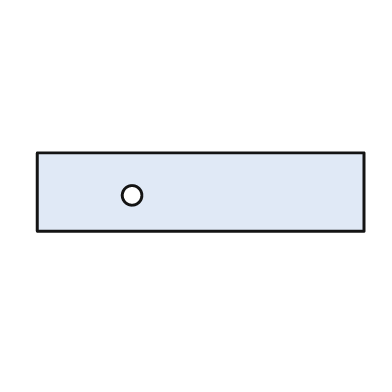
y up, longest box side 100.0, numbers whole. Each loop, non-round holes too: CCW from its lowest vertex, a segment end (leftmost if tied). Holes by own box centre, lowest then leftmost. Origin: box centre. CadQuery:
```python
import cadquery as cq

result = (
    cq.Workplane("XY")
    .moveTo(-50.0, -12.0)
    .lineTo(50.0, -12.0)
    .lineTo(50.0, 12.0)
    .lineTo(-50.0, 12.0)
    .close()
    .moveTo(-21.0, -1.0)
    .circle(3.0)
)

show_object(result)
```